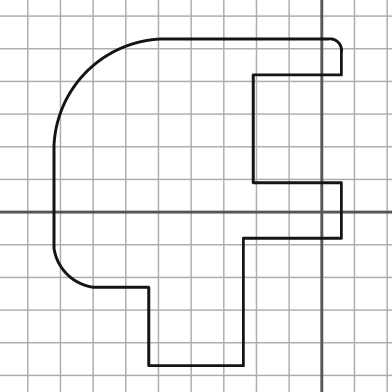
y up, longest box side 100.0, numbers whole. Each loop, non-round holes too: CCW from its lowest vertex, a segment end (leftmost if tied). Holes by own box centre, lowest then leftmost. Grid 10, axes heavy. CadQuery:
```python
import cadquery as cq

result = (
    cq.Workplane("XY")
    .moveTo(-53.0, -47.0)
    .lineTo(-24.0, -47.0)
    .lineTo(-24.0, -8.0)
    .lineTo(6.0, -8.0)
    .lineTo(6.0, 9.0)
    .lineTo(-21.0, 9.0)
    .lineTo(-21.0, 42.0)
    .lineTo(6.0, 42.0)
    .lineTo(6.0, 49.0)
    .threePointArc((5.0, 52.0), (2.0, 53.0))
    .lineTo(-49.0, 53.0)
    .threePointArc((-72.0, 43.0), (-82.0, 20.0))
    .lineTo(-82.0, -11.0)
    .threePointArc((-78.0, -19.0), (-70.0, -23.0))
    .lineTo(-53.0, -23.0)
    .close()
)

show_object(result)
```